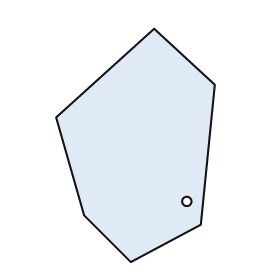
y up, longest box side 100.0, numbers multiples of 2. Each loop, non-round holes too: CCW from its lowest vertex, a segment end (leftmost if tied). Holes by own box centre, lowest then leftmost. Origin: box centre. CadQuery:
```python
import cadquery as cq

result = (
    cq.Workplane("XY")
    .moveTo(-2.0, -50.0)
    .lineTo(28.0, -34.0)
    .lineTo(34.0, 26.0)
    .lineTo(8.0, 50.0)
    .lineTo(-34.0, 12.0)
    .lineTo(-22.0, -30.0)
    .close()
    .moveTo(22.0, -24.0)
    .circle(2.0)
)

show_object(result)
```